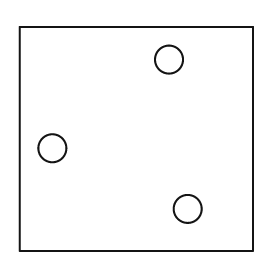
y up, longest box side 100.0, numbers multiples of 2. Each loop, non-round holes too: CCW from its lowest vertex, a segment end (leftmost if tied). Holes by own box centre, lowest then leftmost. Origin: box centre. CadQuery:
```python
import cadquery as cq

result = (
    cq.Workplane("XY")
    .moveTo(-50.0, -48.0)
    .lineTo(50.0, -48.0)
    .lineTo(50.0, 48.0)
    .lineTo(-50.0, 48.0)
    .close()
    .moveTo(22.0, -30.0)
    .circle(6.0)
    .moveTo(-36.0, -4.0)
    .circle(6.0)
    .moveTo(14.0, 34.0)
    .circle(6.0)
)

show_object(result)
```